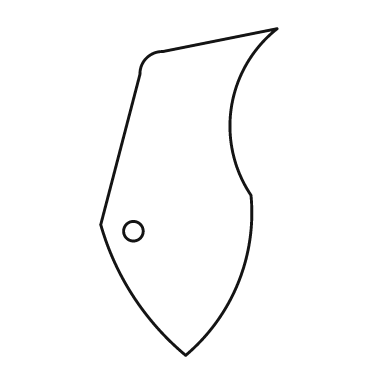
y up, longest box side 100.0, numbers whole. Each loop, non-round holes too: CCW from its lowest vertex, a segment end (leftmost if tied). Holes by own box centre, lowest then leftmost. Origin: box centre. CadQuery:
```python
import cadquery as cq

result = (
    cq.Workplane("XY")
    .moveTo(-1.0, -50.0)
    .threePointArc((15.0, -28.0), (19.0, -1.0))
    .threePointArc((13.0, 26.0), (27.0, 50.0))
    .lineTo(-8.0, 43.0)
    .threePointArc((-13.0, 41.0), (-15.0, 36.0))
    .lineTo(-27.0, -10.0)
    .threePointArc((-17.0, -32.0), (-1.0, -50.0))
    .close()
    .moveTo(-17.0, -12.0)
    .circle(3.0)
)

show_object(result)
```